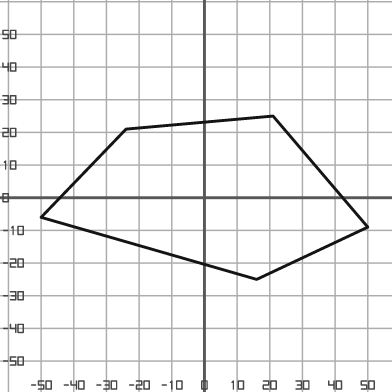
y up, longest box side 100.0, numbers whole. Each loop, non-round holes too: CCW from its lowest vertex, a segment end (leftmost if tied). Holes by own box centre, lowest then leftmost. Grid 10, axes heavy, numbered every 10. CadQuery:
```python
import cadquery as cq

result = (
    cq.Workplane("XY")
    .moveTo(16.0, -25.0)
    .lineTo(50.0, -9.0)
    .lineTo(21.0, 25.0)
    .lineTo(-24.0, 21.0)
    .lineTo(-50.0, -6.0)
    .close()
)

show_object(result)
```